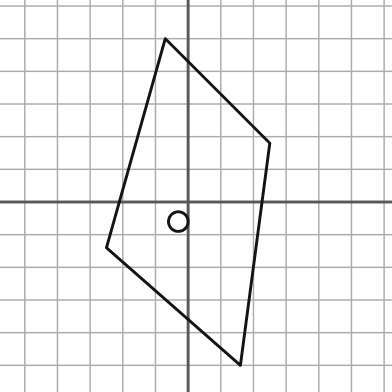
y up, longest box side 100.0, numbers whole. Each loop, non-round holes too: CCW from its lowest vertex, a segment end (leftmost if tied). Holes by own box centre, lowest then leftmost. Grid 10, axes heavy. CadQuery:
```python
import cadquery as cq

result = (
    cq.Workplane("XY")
    .moveTo(16.0, -50.0)
    .lineTo(25.0, 18.0)
    .lineTo(-7.0, 50.0)
    .lineTo(-25.0, -14.0)
    .close()
    .moveTo(-3.0, -6.0)
    .circle(3.0)
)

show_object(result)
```